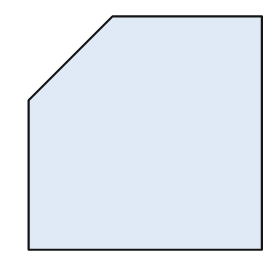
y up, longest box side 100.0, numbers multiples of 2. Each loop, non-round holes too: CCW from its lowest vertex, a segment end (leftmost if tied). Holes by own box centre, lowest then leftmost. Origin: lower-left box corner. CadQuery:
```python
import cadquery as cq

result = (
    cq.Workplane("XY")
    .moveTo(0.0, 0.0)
    .lineTo(100.0, 0.0)
    .lineTo(100.0, 100.0)
    .lineTo(36.0, 100.0)
    .lineTo(0.0, 64.0)
    .close()
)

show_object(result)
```